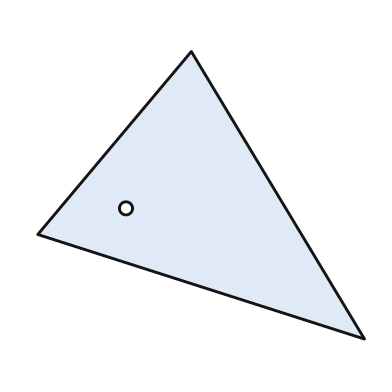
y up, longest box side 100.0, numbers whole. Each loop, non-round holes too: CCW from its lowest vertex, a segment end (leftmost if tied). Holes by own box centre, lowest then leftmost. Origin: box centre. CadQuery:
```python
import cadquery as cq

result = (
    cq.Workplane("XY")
    .moveTo(50.0, -44.0)
    .lineTo(-3.0, 44.0)
    .lineTo(-50.0, -12.0)
    .close()
    .moveTo(-23.0, -4.0)
    .circle(2.0)
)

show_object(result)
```